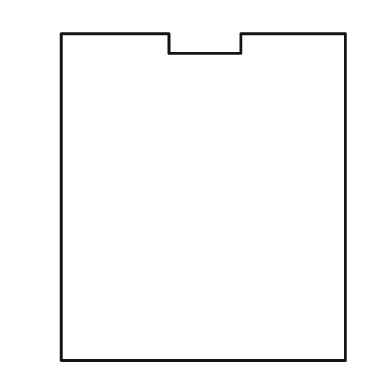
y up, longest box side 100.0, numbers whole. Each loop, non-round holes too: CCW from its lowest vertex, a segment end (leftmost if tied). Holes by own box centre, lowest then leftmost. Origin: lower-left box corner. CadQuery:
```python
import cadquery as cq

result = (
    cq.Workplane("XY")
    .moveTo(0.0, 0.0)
    .lineTo(87.0, 0.0)
    .lineTo(87.0, 100.0)
    .lineTo(55.0, 100.0)
    .lineTo(55.0, 94.0)
    .lineTo(33.0, 94.0)
    .lineTo(33.0, 100.0)
    .lineTo(0.0, 100.0)
    .close()
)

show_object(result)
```